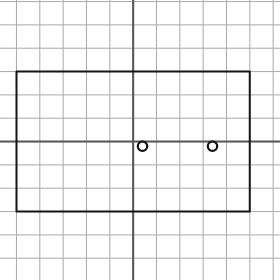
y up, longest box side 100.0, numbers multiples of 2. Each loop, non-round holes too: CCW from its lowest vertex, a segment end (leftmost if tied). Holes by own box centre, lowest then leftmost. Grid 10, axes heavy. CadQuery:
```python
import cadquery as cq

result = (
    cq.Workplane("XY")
    .moveTo(-50.0, -30.0)
    .lineTo(50.0, -30.0)
    .lineTo(50.0, 30.0)
    .lineTo(-50.0, 30.0)
    .close()
    .moveTo(4.0, -2.0)
    .circle(2.0)
    .moveTo(34.0, -2.0)
    .circle(2.0)
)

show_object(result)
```